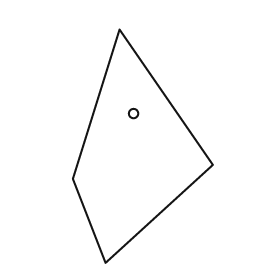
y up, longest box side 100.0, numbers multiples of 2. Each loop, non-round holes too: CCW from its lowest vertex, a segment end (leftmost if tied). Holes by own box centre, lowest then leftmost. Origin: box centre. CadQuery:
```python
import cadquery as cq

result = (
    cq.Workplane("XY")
    .moveTo(-16.0, -50.0)
    .lineTo(30.0, -8.0)
    .lineTo(-10.0, 50.0)
    .lineTo(-30.0, -14.0)
    .close()
    .moveTo(-4.0, 14.0)
    .circle(2.0)
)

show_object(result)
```